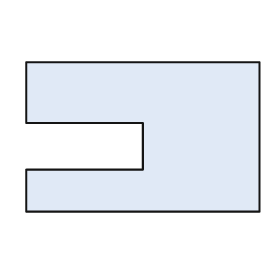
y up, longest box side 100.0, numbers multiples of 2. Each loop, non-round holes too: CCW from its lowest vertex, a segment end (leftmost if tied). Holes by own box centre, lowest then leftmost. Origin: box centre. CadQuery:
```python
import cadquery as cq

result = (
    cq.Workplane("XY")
    .moveTo(-50.0, -32.0)
    .lineTo(50.0, -32.0)
    .lineTo(50.0, 32.0)
    .lineTo(-50.0, 32.0)
    .lineTo(-50.0, 6.0)
    .lineTo(0.0, 6.0)
    .lineTo(0.0, -14.0)
    .lineTo(-50.0, -14.0)
    .close()
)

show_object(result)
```